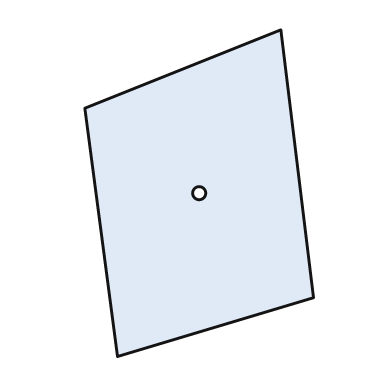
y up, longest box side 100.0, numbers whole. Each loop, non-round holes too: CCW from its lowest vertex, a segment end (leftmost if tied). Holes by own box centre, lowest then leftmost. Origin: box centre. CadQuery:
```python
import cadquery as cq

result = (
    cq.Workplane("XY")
    .moveTo(-25.0, -50.0)
    .lineTo(35.0, -32.0)
    .lineTo(25.0, 50.0)
    .lineTo(-35.0, 26.0)
    .close()
    .moveTo(0.0, 0.0)
    .circle(2.0)
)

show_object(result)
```